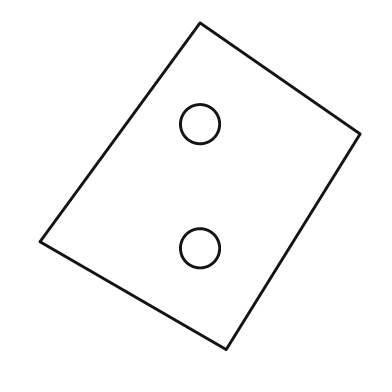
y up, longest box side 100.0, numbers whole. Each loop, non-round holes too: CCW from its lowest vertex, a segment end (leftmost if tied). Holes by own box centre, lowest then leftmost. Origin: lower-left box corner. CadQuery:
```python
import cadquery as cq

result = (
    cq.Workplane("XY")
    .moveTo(57.0, 0.0)
    .lineTo(98.0, 66.0)
    .lineTo(49.0, 100.0)
    .lineTo(0.0, 33.0)
    .close()
    .moveTo(49.0, 31.0)
    .circle(6.0)
    .moveTo(49.0, 69.0)
    .circle(6.0)
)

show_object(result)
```